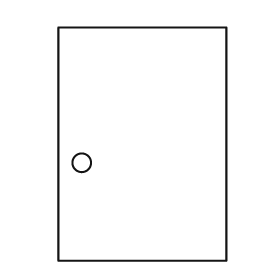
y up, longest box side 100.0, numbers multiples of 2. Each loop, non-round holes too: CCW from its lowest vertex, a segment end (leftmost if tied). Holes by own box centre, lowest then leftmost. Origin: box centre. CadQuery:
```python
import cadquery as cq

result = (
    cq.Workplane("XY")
    .moveTo(-36.0, -50.0)
    .lineTo(36.0, -50.0)
    .lineTo(36.0, 50.0)
    .lineTo(-36.0, 50.0)
    .close()
    .moveTo(-26.0, -8.0)
    .circle(4.0)
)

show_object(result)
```